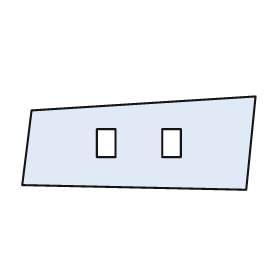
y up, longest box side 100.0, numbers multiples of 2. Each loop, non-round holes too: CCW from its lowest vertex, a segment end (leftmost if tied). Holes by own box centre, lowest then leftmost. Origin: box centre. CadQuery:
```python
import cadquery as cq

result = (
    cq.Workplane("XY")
    .moveTo(46.0, -20.0)
    .lineTo(50.0, 20.0)
    .lineTo(-46.0, 14.0)
    .lineTo(-50.0, -18.0)
    .close()
    .moveTo(-18.0, -6.0)
    .lineTo(-10.0, -6.0)
    .lineTo(-10.0, 6.0)
    .lineTo(-18.0, 6.0)
    .close()
    .moveTo(10.0, -6.0)
    .lineTo(18.0, -6.0)
    .lineTo(18.0, 6.0)
    .lineTo(10.0, 6.0)
    .close()
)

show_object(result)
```